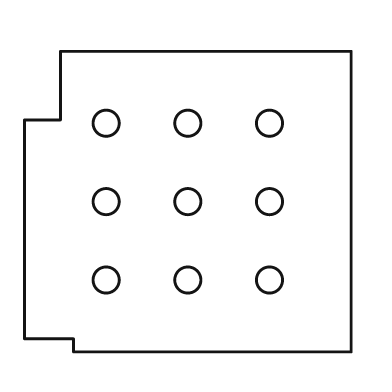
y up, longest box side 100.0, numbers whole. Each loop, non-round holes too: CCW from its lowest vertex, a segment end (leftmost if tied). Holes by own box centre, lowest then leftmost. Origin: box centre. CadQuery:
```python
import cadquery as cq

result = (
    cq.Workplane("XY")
    .moveTo(-35.0, -46.0)
    .lineTo(50.0, -46.0)
    .lineTo(50.0, 46.0)
    .lineTo(-39.0, 46.0)
    .lineTo(-39.0, 25.0)
    .lineTo(-50.0, 25.0)
    .lineTo(-50.0, -42.0)
    .lineTo(-35.0, -42.0)
    .close()
    .moveTo(-25.0, -24.0)
    .circle(4.0)
    .moveTo(0.0, -24.0)
    .circle(4.0)
    .moveTo(25.0, -24.0)
    .circle(4.0)
    .moveTo(-25.0, 0.0)
    .circle(4.0)
    .moveTo(0.0, 0.0)
    .circle(4.0)
    .moveTo(25.0, 0.0)
    .circle(4.0)
    .moveTo(-25.0, 24.0)
    .circle(4.0)
    .moveTo(0.0, 24.0)
    .circle(4.0)
    .moveTo(25.0, 24.0)
    .circle(4.0)
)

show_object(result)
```